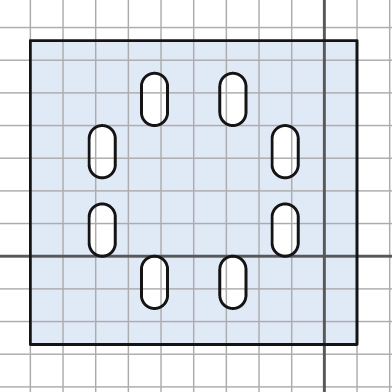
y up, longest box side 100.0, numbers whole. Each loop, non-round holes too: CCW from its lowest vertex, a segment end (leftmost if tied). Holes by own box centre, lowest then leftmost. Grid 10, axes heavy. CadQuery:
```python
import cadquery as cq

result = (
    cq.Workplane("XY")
    .moveTo(-90.0, -27.0)
    .lineTo(10.0, -27.0)
    .lineTo(10.0, 66.0)
    .lineTo(-90.0, 66.0)
    .close()
    .moveTo(-56.0, -12.0)
    .threePointArc((-52.0, -16.0), (-48.0, -12.0))
    .lineTo(-48.0, -4.0)
    .threePointArc((-52.0, 0.0), (-56.0, -4.0))
    .close()
    .moveTo(-32.0, -12.0)
    .threePointArc((-28.0, -16.0), (-24.0, -12.0))
    .lineTo(-24.0, -4.0)
    .threePointArc((-28.0, 0.0), (-32.0, -4.0))
    .close()
    .moveTo(-72.0, 4.0)
    .threePointArc((-68.0, 0.0), (-64.0, 4.0))
    .lineTo(-64.0, 12.0)
    .threePointArc((-68.0, 16.0), (-72.0, 12.0))
    .close()
    .moveTo(-16.0, 4.0)
    .threePointArc((-12.0, 0.0), (-8.0, 4.0))
    .lineTo(-8.0, 12.0)
    .threePointArc((-12.0, 16.0), (-16.0, 12.0))
    .close()
    .moveTo(-72.0, 28.0)
    .threePointArc((-68.0, 24.0), (-64.0, 28.0))
    .lineTo(-64.0, 36.0)
    .threePointArc((-68.0, 40.0), (-72.0, 36.0))
    .close()
    .moveTo(-16.0, 28.0)
    .threePointArc((-12.0, 24.0), (-8.0, 28.0))
    .lineTo(-8.0, 36.0)
    .threePointArc((-12.0, 40.0), (-16.0, 36.0))
    .close()
    .moveTo(-56.0, 44.0)
    .threePointArc((-52.0, 40.0), (-48.0, 44.0))
    .lineTo(-48.0, 52.0)
    .threePointArc((-52.0, 56.0), (-56.0, 52.0))
    .close()
    .moveTo(-32.0, 44.0)
    .threePointArc((-28.0, 40.0), (-24.0, 44.0))
    .lineTo(-24.0, 52.0)
    .threePointArc((-28.0, 56.0), (-32.0, 52.0))
    .close()
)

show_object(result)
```